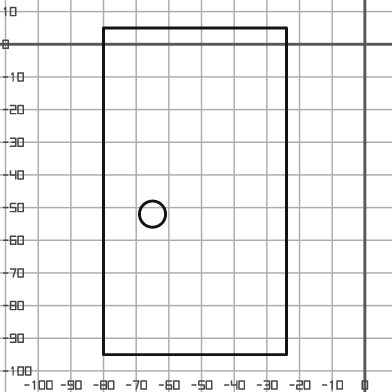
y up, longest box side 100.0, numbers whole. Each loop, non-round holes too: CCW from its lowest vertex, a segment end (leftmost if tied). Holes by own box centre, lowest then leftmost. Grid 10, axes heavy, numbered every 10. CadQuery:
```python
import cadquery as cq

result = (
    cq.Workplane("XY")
    .moveTo(-80.0, -95.0)
    .lineTo(-24.0, -95.0)
    .lineTo(-24.0, 5.0)
    .lineTo(-80.0, 5.0)
    .close()
    .moveTo(-65.0, -52.0)
    .circle(4.0)
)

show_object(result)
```